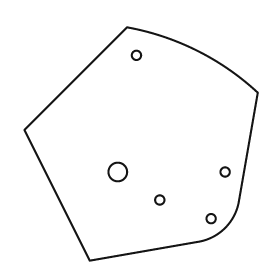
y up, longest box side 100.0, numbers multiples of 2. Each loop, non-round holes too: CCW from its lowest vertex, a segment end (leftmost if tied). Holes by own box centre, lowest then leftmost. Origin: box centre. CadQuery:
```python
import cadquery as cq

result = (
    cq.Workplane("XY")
    .moveTo(-22.0, -50.0)
    .lineTo(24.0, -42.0)
    .threePointArc((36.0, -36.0), (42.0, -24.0))
    .lineTo(50.0, 22.0)
    .threePointArc((24.0, 40.0), (-6.0, 50.0))
    .lineTo(-50.0, 6.0)
    .close()
    .moveTo(30.0, -32.0)
    .circle(2.0)
    .moveTo(8.0, -24.0)
    .circle(2.0)
    .moveTo(-10.0, -12.0)
    .circle(4.0)
    .moveTo(36.0, -12.0)
    .circle(2.0)
    .moveTo(-2.0, 38.0)
    .circle(2.0)
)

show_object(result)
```